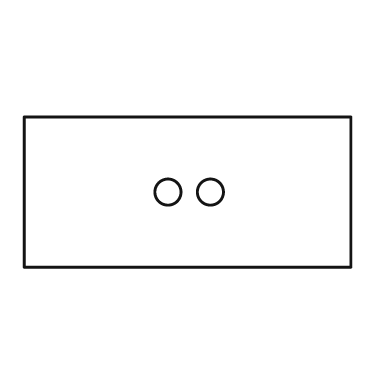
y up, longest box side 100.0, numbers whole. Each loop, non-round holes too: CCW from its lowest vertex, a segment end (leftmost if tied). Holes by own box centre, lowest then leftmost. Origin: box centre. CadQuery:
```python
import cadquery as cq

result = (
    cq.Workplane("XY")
    .moveTo(-50.0, -23.0)
    .lineTo(50.0, -23.0)
    .lineTo(50.0, 23.0)
    .lineTo(-50.0, 23.0)
    .close()
    .moveTo(-6.0, 0.0)
    .circle(4.0)
    .moveTo(7.0, 0.0)
    .circle(4.0)
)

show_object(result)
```